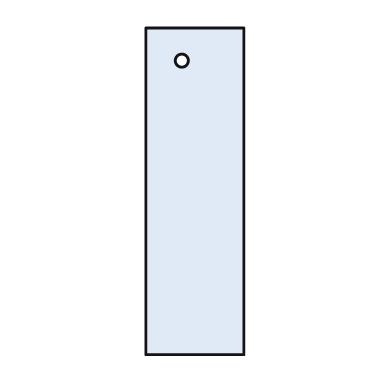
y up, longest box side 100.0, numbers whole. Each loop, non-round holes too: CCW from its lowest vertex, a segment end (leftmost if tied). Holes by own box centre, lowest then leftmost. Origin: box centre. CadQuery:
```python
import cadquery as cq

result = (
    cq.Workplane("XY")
    .moveTo(-15.0, -50.0)
    .lineTo(15.0, -50.0)
    .lineTo(15.0, 50.0)
    .lineTo(-15.0, 50.0)
    .close()
    .moveTo(-4.0, 40.0)
    .circle(2.0)
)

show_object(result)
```